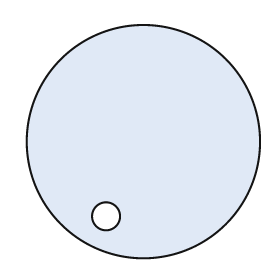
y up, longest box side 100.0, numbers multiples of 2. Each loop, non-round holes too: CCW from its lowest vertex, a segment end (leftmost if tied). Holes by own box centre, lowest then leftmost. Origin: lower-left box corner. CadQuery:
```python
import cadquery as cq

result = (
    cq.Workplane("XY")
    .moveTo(50.0, 50.0)
    .circle(50.0)
    .moveTo(34.0, 18.0)
    .circle(6.0)
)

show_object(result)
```